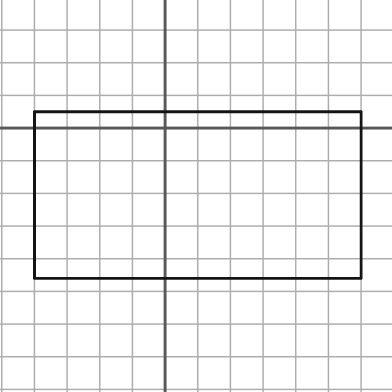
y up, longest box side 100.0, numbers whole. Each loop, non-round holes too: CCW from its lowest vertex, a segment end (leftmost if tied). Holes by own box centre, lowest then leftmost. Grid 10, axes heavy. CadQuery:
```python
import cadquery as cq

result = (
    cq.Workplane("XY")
    .moveTo(-40.0, -46.0)
    .lineTo(60.0, -46.0)
    .lineTo(60.0, 5.0)
    .lineTo(-40.0, 5.0)
    .close()
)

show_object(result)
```